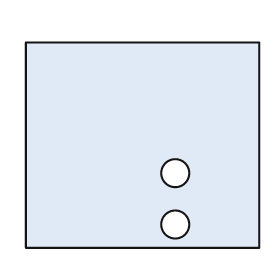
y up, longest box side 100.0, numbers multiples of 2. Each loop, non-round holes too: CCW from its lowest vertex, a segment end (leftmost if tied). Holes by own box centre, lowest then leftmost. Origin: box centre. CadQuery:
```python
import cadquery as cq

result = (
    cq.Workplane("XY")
    .moveTo(-50.0, -44.0)
    .lineTo(50.0, -44.0)
    .lineTo(50.0, 44.0)
    .lineTo(-50.0, 44.0)
    .close()
    .moveTo(14.0, -34.0)
    .circle(6.0)
    .moveTo(14.0, -12.0)
    .circle(6.0)
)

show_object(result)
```